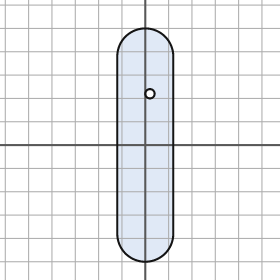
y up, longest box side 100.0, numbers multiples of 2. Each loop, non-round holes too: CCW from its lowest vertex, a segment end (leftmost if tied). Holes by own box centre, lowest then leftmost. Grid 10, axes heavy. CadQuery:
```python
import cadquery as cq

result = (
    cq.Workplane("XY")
    .moveTo(-12.0, -38.0)
    .threePointArc((0.0, -50.0), (12.0, -38.0))
    .lineTo(12.0, 38.0)
    .threePointArc((0.0, 50.0), (-12.0, 38.0))
    .close()
    .moveTo(2.0, 22.0)
    .circle(2.0)
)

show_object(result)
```